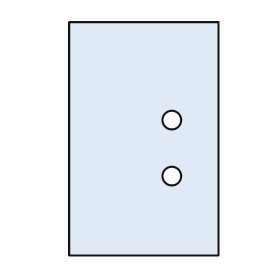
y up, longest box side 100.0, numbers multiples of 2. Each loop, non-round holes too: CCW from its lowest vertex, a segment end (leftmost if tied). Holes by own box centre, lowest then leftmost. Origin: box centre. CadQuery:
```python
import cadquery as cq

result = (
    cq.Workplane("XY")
    .moveTo(-32.0, -50.0)
    .lineTo(32.0, -50.0)
    .lineTo(32.0, 50.0)
    .lineTo(-32.0, 50.0)
    .close()
    .moveTo(12.0, -16.0)
    .circle(4.0)
    .moveTo(12.0, 8.0)
    .circle(4.0)
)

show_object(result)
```